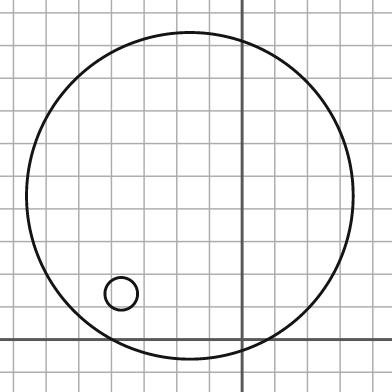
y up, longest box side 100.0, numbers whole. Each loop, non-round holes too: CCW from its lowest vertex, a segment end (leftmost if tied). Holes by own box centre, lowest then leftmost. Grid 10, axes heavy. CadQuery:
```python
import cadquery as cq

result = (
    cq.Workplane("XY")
    .moveTo(-16.0, 44.0)
    .circle(50.0)
    .moveTo(-37.0, 14.0)
    .circle(5.0)
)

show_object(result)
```